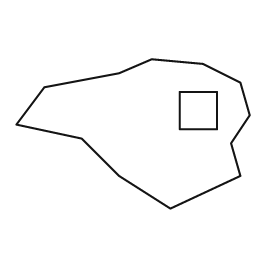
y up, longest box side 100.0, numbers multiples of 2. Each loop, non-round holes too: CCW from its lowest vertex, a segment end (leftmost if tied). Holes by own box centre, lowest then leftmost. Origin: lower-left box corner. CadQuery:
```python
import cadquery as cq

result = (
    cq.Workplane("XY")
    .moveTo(66.0, 0.0)
    .lineTo(96.0, 14.0)
    .lineTo(92.0, 28.0)
    .lineTo(100.0, 40.0)
    .lineTo(96.0, 54.0)
    .lineTo(80.0, 62.0)
    .lineTo(58.0, 64.0)
    .lineTo(44.0, 58.0)
    .lineTo(12.0, 52.0)
    .lineTo(0.0, 36.0)
    .lineTo(28.0, 30.0)
    .lineTo(44.0, 14.0)
    .close()
    .moveTo(70.0, 34.0)
    .lineTo(86.0, 34.0)
    .lineTo(86.0, 50.0)
    .lineTo(70.0, 50.0)
    .close()
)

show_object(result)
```